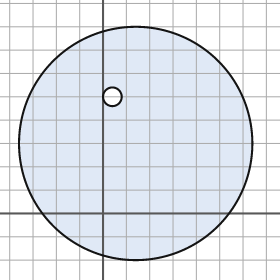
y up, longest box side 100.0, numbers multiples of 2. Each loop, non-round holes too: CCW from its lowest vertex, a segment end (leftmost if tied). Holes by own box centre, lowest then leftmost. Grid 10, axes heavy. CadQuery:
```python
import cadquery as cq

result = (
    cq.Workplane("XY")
    .moveTo(14.0, 30.0)
    .circle(50.0)
    .moveTo(4.0, 50.0)
    .circle(4.0)
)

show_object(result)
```